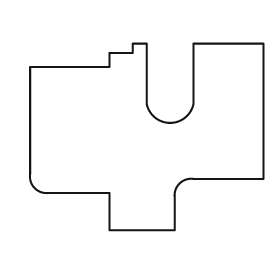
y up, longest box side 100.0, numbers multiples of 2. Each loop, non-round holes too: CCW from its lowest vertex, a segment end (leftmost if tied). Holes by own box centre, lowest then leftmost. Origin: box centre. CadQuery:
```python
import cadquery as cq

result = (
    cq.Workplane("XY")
    .moveTo(-16.0, -40.0)
    .lineTo(12.0, -40.0)
    .lineTo(12.0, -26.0)
    .threePointArc((14.0, -20.0), (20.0, -18.0))
    .lineTo(50.0, -18.0)
    .lineTo(50.0, 40.0)
    .lineTo(20.0, 40.0)
    .lineTo(20.0, 14.0)
    .threePointArc((10.0, 6.0), (0.0, 14.0))
    .lineTo(0.0, 40.0)
    .lineTo(-6.0, 40.0)
    .lineTo(-6.0, 36.0)
    .lineTo(-16.0, 36.0)
    .lineTo(-16.0, 30.0)
    .lineTo(-50.0, 30.0)
    .lineTo(-50.0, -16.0)
    .threePointArc((-48.0, -22.0), (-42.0, -24.0))
    .lineTo(-16.0, -24.0)
    .close()
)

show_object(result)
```